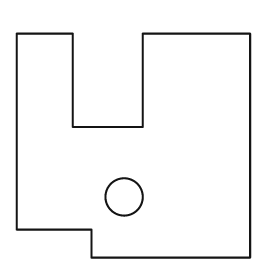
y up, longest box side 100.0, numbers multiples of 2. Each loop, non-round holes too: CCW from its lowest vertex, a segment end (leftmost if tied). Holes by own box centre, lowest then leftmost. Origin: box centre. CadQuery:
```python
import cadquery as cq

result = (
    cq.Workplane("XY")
    .moveTo(-18.0, -48.0)
    .lineTo(50.0, -48.0)
    .lineTo(50.0, 48.0)
    .lineTo(4.0, 48.0)
    .lineTo(4.0, 8.0)
    .lineTo(-26.0, 8.0)
    .lineTo(-26.0, 48.0)
    .lineTo(-50.0, 48.0)
    .lineTo(-50.0, -36.0)
    .lineTo(-18.0, -36.0)
    .close()
    .moveTo(-4.0, -22.0)
    .circle(8.0)
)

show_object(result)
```